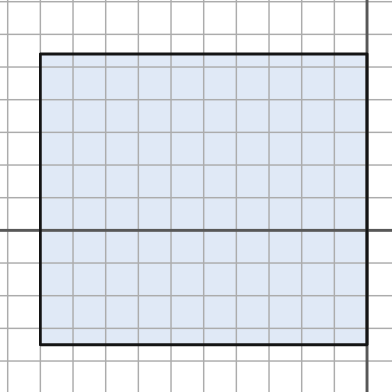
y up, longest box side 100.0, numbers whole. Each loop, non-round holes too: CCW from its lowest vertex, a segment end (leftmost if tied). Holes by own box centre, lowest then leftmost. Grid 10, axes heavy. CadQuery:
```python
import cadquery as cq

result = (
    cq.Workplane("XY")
    .moveTo(-100.0, -35.0)
    .lineTo(0.0, -35.0)
    .lineTo(0.0, 54.0)
    .lineTo(-100.0, 54.0)
    .close()
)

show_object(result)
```